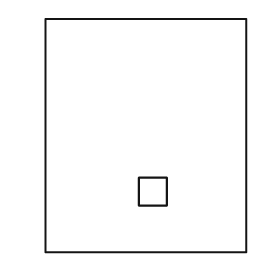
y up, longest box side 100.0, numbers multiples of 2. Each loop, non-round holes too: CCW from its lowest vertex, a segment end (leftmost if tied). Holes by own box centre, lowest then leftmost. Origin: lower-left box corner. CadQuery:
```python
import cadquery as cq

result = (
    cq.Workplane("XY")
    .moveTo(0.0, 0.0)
    .lineTo(86.0, 0.0)
    .lineTo(86.0, 100.0)
    .lineTo(0.0, 100.0)
    .close()
    .moveTo(40.0, 20.0)
    .lineTo(52.0, 20.0)
    .lineTo(52.0, 32.0)
    .lineTo(40.0, 32.0)
    .close()
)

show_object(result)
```